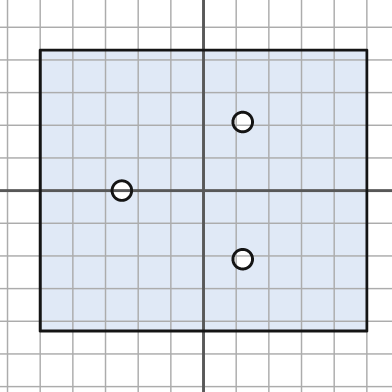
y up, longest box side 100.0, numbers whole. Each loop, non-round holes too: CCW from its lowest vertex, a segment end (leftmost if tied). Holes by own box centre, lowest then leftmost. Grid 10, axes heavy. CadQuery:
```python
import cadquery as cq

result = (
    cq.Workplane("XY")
    .moveTo(-50.0, -43.0)
    .lineTo(50.0, -43.0)
    .lineTo(50.0, 43.0)
    .lineTo(-50.0, 43.0)
    .close()
    .moveTo(12.0, -21.0)
    .circle(3.0)
    .moveTo(-25.0, 0.0)
    .circle(3.0)
    .moveTo(12.0, 21.0)
    .circle(3.0)
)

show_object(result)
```